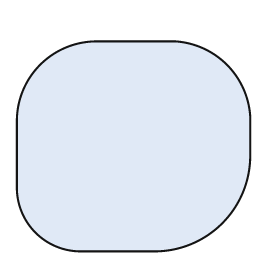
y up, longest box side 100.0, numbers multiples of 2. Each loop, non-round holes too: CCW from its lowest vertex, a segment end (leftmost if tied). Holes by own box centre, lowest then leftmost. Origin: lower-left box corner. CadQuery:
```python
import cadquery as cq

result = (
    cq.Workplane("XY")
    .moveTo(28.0, 0.0)
    .lineTo(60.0, 0.0)
    .threePointArc((88.0, 12.0), (100.0, 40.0))
    .lineTo(100.0, 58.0)
    .threePointArc((90.0, 80.0), (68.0, 90.0))
    .lineTo(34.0, 90.0)
    .threePointArc((10.0, 80.0), (0.0, 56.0))
    .lineTo(0.0, 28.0)
    .threePointArc((8.0, 8.0), (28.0, 0.0))
    .close()
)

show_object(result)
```